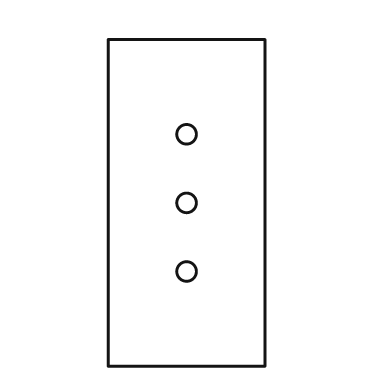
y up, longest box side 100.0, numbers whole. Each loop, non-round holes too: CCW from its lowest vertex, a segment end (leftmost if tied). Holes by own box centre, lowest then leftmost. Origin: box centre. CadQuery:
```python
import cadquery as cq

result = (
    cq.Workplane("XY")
    .moveTo(-24.0, -50.0)
    .lineTo(24.0, -50.0)
    .lineTo(24.0, 50.0)
    .lineTo(-24.0, 50.0)
    .close()
    .moveTo(0.0, -21.0)
    .circle(3.0)
    .moveTo(0.0, 0.0)
    .circle(3.0)
    .moveTo(0.0, 21.0)
    .circle(3.0)
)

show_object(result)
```